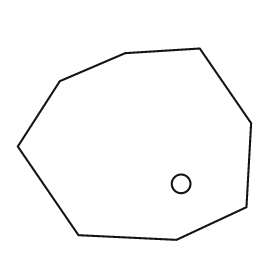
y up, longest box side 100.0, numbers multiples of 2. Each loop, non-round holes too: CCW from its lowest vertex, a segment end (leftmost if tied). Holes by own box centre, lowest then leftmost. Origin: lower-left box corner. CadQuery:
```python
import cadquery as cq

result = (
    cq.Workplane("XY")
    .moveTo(68.0, 0.0)
    .lineTo(98.0, 14.0)
    .lineTo(100.0, 50.0)
    .lineTo(78.0, 82.0)
    .lineTo(46.0, 80.0)
    .lineTo(18.0, 68.0)
    .lineTo(0.0, 40.0)
    .lineTo(26.0, 2.0)
    .close()
    .moveTo(70.0, 24.0)
    .circle(4.0)
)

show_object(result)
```